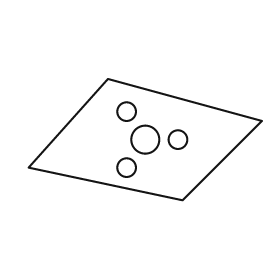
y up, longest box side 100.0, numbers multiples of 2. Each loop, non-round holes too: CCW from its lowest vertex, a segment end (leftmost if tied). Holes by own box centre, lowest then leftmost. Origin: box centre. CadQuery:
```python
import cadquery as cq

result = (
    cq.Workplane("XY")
    .moveTo(16.0, -26.0)
    .lineTo(50.0, 8.0)
    .lineTo(-16.0, 26.0)
    .lineTo(-50.0, -12.0)
    .close()
    .moveTo(-8.0, -12.0)
    .circle(4.0)
    .moveTo(0.0, 0.0)
    .circle(6.0)
    .moveTo(14.0, 0.0)
    .circle(4.0)
    .moveTo(-8.0, 12.0)
    .circle(4.0)
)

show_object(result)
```